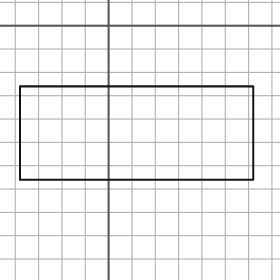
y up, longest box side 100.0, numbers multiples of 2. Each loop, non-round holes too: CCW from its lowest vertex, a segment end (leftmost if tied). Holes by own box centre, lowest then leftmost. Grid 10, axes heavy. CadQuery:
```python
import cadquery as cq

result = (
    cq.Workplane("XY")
    .moveTo(-38.0, -66.0)
    .lineTo(62.0, -66.0)
    .lineTo(62.0, -26.0)
    .lineTo(-38.0, -26.0)
    .close()
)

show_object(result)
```